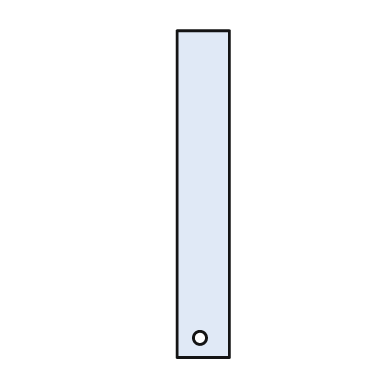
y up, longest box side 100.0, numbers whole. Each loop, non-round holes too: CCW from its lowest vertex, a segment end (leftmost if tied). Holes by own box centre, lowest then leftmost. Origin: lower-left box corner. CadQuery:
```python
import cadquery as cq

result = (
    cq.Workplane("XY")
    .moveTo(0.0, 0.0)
    .lineTo(16.0, 0.0)
    .lineTo(16.0, 100.0)
    .lineTo(0.0, 100.0)
    .close()
    .moveTo(7.0, 6.0)
    .circle(2.0)
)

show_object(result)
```